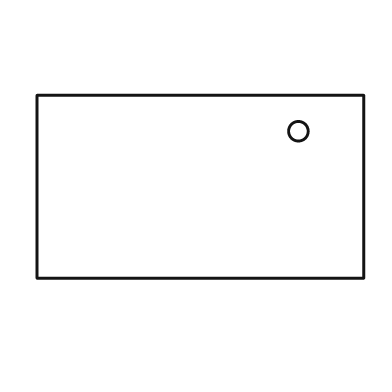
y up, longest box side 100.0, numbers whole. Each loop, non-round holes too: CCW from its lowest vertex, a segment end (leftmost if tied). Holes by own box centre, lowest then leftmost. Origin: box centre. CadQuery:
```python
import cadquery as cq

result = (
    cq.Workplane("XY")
    .moveTo(-50.0, -28.0)
    .lineTo(50.0, -28.0)
    .lineTo(50.0, 28.0)
    .lineTo(-50.0, 28.0)
    .close()
    .moveTo(30.0, 17.0)
    .circle(3.0)
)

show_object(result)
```